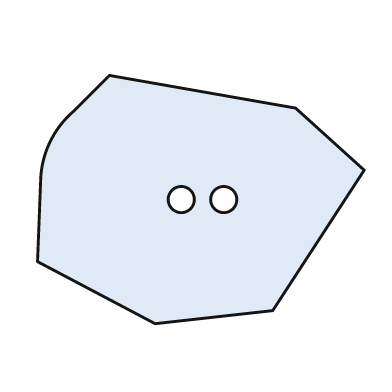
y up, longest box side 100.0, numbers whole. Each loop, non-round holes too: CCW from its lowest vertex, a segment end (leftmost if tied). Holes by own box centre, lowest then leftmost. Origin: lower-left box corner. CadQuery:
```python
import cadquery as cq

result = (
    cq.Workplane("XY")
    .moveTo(36.0, 0.0)
    .lineTo(72.0, 4.0)
    .lineTo(100.0, 47.0)
    .lineTo(79.0, 66.0)
    .lineTo(22.0, 76.0)
    .lineTo(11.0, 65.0)
    .threePointArc((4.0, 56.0), (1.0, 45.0))
    .lineTo(0.0, 19.0)
    .close()
    .moveTo(44.0, 38.0)
    .circle(4.0)
    .moveTo(57.0, 38.0)
    .circle(4.0)
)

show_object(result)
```